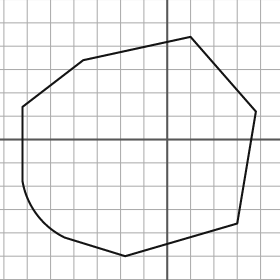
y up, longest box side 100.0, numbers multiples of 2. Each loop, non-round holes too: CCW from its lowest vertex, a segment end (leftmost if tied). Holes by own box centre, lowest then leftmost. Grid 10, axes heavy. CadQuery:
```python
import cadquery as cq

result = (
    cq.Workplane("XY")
    .moveTo(-18.0, -50.0)
    .lineTo(30.0, -36.0)
    .lineTo(38.0, 12.0)
    .lineTo(10.0, 44.0)
    .lineTo(-36.0, 34.0)
    .lineTo(-62.0, 14.0)
    .lineTo(-62.0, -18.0)
    .threePointArc((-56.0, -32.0), (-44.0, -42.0))
    .close()
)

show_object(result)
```